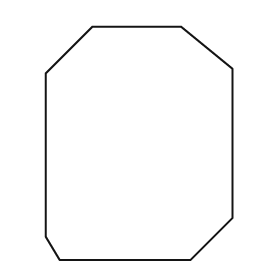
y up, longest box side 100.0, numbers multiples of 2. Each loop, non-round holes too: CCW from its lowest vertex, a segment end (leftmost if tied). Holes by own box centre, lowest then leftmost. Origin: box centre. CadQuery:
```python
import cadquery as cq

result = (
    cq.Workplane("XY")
    .moveTo(-34.0, -50.0)
    .lineTo(22.0, -50.0)
    .lineTo(40.0, -32.0)
    .lineTo(40.0, 32.0)
    .lineTo(18.0, 50.0)
    .lineTo(-20.0, 50.0)
    .lineTo(-40.0, 30.0)
    .lineTo(-40.0, -40.0)
    .close()
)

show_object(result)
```